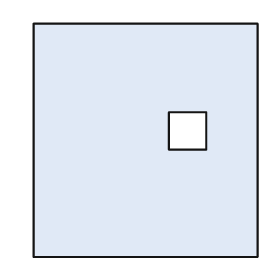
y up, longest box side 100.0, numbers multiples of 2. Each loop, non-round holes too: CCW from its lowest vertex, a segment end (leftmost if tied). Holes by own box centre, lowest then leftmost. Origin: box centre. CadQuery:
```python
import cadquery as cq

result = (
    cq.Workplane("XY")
    .moveTo(-48.0, -50.0)
    .lineTo(48.0, -50.0)
    .lineTo(48.0, 50.0)
    .lineTo(-48.0, 50.0)
    .close()
    .moveTo(10.0, -4.0)
    .lineTo(26.0, -4.0)
    .lineTo(26.0, 12.0)
    .lineTo(10.0, 12.0)
    .close()
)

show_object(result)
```